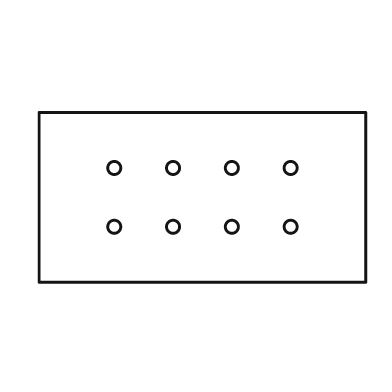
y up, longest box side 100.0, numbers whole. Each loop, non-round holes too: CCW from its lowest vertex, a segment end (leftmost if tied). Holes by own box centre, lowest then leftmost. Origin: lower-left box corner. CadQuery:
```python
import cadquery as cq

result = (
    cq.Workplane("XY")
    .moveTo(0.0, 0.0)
    .lineTo(100.0, 0.0)
    .lineTo(100.0, 52.0)
    .lineTo(0.0, 52.0)
    .close()
    .moveTo(23.0, 17.0)
    .circle(2.0)
    .moveTo(41.0, 17.0)
    .circle(2.0)
    .moveTo(59.0, 17.0)
    .circle(2.0)
    .moveTo(77.0, 17.0)
    .circle(2.0)
    .moveTo(23.0, 35.0)
    .circle(2.0)
    .moveTo(41.0, 35.0)
    .circle(2.0)
    .moveTo(59.0, 35.0)
    .circle(2.0)
    .moveTo(77.0, 35.0)
    .circle(2.0)
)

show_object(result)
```